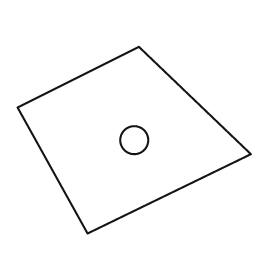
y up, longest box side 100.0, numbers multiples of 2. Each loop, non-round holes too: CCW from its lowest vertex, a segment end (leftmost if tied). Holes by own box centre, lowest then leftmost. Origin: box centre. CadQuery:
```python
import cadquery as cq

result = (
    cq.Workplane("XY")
    .moveTo(-20.0, -40.0)
    .lineTo(50.0, -6.0)
    .lineTo(2.0, 40.0)
    .lineTo(-50.0, 14.0)
    .close()
    .moveTo(0.0, 0.0)
    .circle(6.0)
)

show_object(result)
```